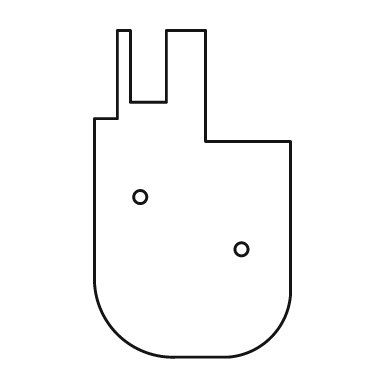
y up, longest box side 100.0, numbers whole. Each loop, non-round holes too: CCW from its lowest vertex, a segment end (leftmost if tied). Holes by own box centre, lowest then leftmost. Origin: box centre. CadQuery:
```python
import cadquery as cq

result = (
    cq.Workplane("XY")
    .moveTo(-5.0, -50.0)
    .lineTo(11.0, -50.0)
    .threePointArc((24.0, -44.0), (30.0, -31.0))
    .lineTo(30.0, 16.0)
    .lineTo(4.0, 16.0)
    .lineTo(4.0, 50.0)
    .lineTo(-8.0, 50.0)
    .lineTo(-8.0, 28.0)
    .lineTo(-19.0, 28.0)
    .lineTo(-19.0, 50.0)
    .lineTo(-23.0, 50.0)
    .lineTo(-23.0, 23.0)
    .lineTo(-30.0, 23.0)
    .lineTo(-30.0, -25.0)
    .threePointArc((-23.0, -43.0), (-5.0, -50.0))
    .close()
    .moveTo(15.0, -17.0)
    .circle(2.0)
    .moveTo(-16.0, -1.0)
    .circle(2.0)
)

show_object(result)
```